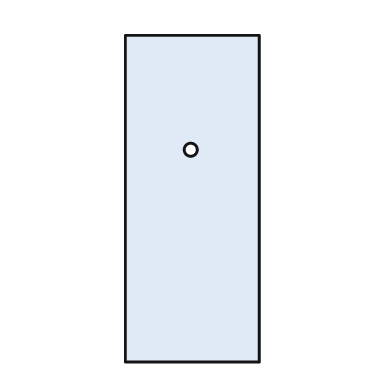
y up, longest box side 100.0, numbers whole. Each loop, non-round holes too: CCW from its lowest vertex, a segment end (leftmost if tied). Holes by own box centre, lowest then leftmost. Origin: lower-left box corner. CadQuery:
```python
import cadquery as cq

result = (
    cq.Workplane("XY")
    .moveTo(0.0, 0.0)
    .lineTo(41.0, 0.0)
    .lineTo(41.0, 100.0)
    .lineTo(0.0, 100.0)
    .close()
    .moveTo(20.0, 65.0)
    .circle(2.0)
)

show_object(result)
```